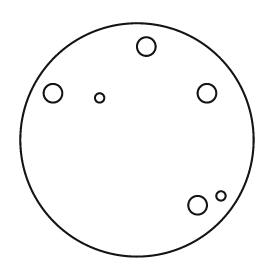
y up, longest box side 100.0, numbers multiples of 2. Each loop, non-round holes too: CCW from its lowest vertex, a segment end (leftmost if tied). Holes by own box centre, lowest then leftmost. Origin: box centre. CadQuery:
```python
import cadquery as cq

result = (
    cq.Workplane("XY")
    .moveTo(0.0, 0.0)
    .circle(50.0)
    .moveTo(26.0, -28.0)
    .circle(4.0)
    .moveTo(36.0, -24.0)
    .circle(2.0)
    .moveTo(-16.0, 18.0)
    .circle(2.0)
    .moveTo(-36.0, 20.0)
    .circle(4.0)
    .moveTo(30.0, 20.0)
    .circle(4.0)
    .moveTo(4.0, 40.0)
    .circle(4.0)
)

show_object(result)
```